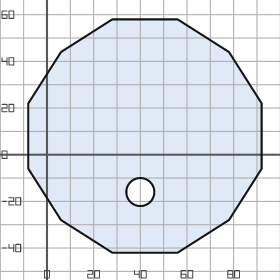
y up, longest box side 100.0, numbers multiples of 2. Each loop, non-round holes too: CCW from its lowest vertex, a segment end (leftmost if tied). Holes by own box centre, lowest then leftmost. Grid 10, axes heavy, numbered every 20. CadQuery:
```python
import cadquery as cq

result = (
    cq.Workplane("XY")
    .moveTo(28.0, -42.0)
    .lineTo(56.0, -42.0)
    .lineTo(78.0, -28.0)
    .lineTo(92.0, -6.0)
    .lineTo(92.0, 22.0)
    .lineTo(78.0, 44.0)
    .lineTo(56.0, 58.0)
    .lineTo(28.0, 58.0)
    .lineTo(6.0, 44.0)
    .lineTo(-8.0, 22.0)
    .lineTo(-8.0, -6.0)
    .lineTo(6.0, -28.0)
    .close()
    .moveTo(40.0, -16.0)
    .circle(6.0)
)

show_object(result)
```